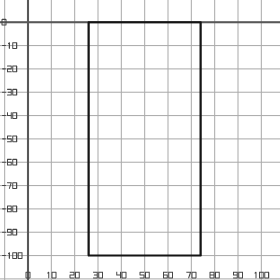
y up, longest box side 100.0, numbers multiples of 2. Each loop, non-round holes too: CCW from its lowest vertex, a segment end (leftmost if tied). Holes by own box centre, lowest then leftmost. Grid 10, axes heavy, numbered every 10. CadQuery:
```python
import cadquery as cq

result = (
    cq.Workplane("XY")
    .moveTo(26.0, -100.0)
    .lineTo(74.0, -100.0)
    .lineTo(74.0, 0.0)
    .lineTo(26.0, 0.0)
    .close()
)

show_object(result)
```